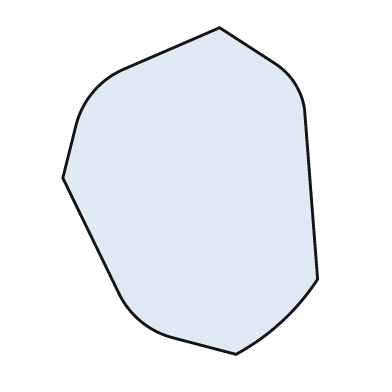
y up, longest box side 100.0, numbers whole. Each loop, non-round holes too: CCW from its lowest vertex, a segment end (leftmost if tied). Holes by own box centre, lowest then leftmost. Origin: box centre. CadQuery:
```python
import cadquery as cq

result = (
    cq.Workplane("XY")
    .moveTo(14.0, -50.0)
    .threePointArc((28.0, -40.0), (39.0, -27.0))
    .lineTo(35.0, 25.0)
    .threePointArc((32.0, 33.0), (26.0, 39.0))
    .lineTo(9.0, 50.0)
    .lineTo(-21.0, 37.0)
    .threePointArc((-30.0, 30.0), (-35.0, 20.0))
    .lineTo(-39.0, 4.0)
    .lineTo(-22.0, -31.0)
    .threePointArc((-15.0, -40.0), (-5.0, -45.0))
    .close()
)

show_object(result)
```